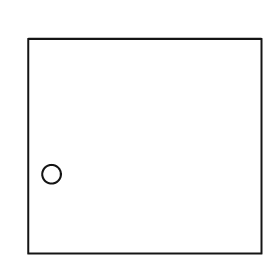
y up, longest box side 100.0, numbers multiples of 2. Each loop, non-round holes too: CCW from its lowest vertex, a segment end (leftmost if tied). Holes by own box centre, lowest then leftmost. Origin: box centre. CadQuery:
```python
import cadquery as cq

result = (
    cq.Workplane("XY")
    .moveTo(-50.0, -46.0)
    .lineTo(50.0, -46.0)
    .lineTo(50.0, 46.0)
    .lineTo(-50.0, 46.0)
    .close()
    .moveTo(-40.0, -12.0)
    .circle(4.0)
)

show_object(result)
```